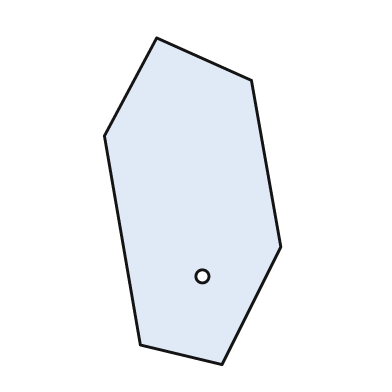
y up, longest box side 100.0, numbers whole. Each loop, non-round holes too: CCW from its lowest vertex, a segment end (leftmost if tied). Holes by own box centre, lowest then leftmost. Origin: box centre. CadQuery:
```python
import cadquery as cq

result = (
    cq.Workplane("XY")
    .moveTo(9.0, -50.0)
    .lineTo(27.0, -14.0)
    .lineTo(18.0, 37.0)
    .lineTo(-11.0, 50.0)
    .lineTo(-27.0, 20.0)
    .lineTo(-16.0, -44.0)
    .close()
    .moveTo(3.0, -23.0)
    .circle(2.0)
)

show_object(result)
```